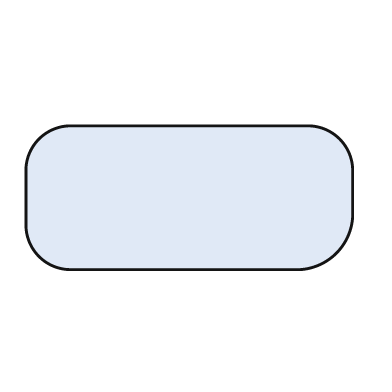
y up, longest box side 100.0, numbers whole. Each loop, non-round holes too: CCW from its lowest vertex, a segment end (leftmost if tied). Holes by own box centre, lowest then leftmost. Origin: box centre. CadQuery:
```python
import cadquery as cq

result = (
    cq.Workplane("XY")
    .moveTo(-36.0, -22.0)
    .lineTo(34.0, -22.0)
    .threePointArc((45.0, -17.0), (50.0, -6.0))
    .lineTo(50.0, 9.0)
    .threePointArc((46.0, 18.0), (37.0, 22.0))
    .lineTo(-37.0, 22.0)
    .threePointArc((-46.0, 18.0), (-50.0, 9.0))
    .lineTo(-50.0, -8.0)
    .threePointArc((-46.0, -18.0), (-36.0, -22.0))
    .close()
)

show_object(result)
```